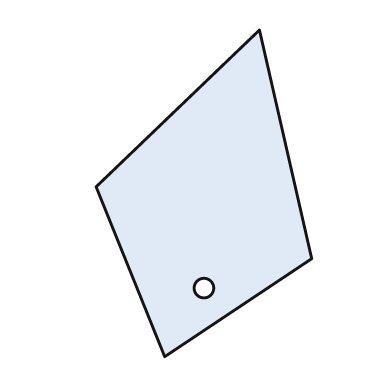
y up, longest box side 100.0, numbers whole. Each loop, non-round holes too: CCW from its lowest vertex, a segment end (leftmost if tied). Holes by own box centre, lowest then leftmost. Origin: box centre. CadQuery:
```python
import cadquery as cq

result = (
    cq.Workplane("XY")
    .moveTo(-12.0, -50.0)
    .lineTo(33.0, -20.0)
    .lineTo(17.0, 50.0)
    .lineTo(-33.0, 2.0)
    .close()
    .moveTo(0.0, -29.0)
    .circle(3.0)
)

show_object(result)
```